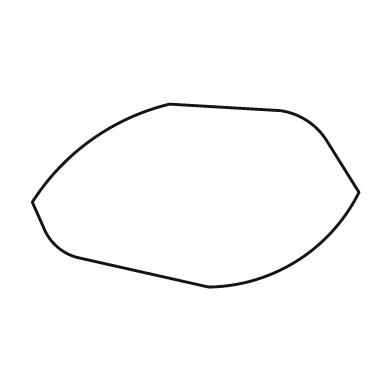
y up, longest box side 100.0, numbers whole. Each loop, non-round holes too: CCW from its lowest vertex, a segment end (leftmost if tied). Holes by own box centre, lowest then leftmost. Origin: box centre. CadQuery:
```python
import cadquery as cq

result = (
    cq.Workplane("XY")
    .moveTo(4.0, -28.0)
    .threePointArc((31.0, -20.0), (50.0, 1.0))
    .lineTo(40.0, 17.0)
    .threePointArc((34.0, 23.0), (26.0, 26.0))
    .lineTo(-8.0, 28.0)
    .threePointArc((-32.0, 17.0), (-50.0, -2.0))
    .lineTo(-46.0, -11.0)
    .threePointArc((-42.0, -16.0), (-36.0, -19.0))
    .close()
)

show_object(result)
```